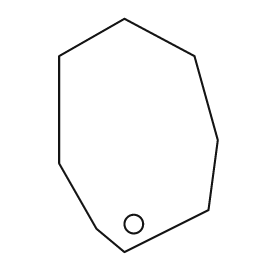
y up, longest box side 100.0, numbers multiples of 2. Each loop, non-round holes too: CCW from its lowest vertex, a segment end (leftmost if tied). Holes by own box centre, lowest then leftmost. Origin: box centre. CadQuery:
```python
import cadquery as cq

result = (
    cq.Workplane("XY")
    .moveTo(-6.0, -50.0)
    .lineTo(30.0, -32.0)
    .lineTo(34.0, -2.0)
    .lineTo(24.0, 34.0)
    .lineTo(-6.0, 50.0)
    .lineTo(-34.0, 34.0)
    .lineTo(-34.0, -12.0)
    .lineTo(-18.0, -40.0)
    .close()
    .moveTo(-2.0, -38.0)
    .circle(4.0)
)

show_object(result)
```